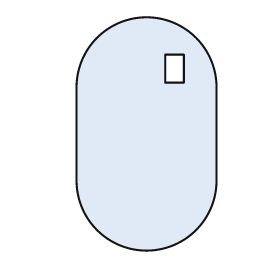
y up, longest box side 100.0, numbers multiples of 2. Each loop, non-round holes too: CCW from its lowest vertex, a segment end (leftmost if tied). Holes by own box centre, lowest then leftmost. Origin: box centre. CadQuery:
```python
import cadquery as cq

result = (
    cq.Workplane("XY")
    .moveTo(-30.0, -20.0)
    .threePointArc((0.0, -50.0), (30.0, -20.0))
    .lineTo(30.0, 20.0)
    .threePointArc((0.0, 50.0), (-30.0, 20.0))
    .close()
    .moveTo(8.0, 22.0)
    .lineTo(16.0, 22.0)
    .lineTo(16.0, 34.0)
    .lineTo(8.0, 34.0)
    .close()
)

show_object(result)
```